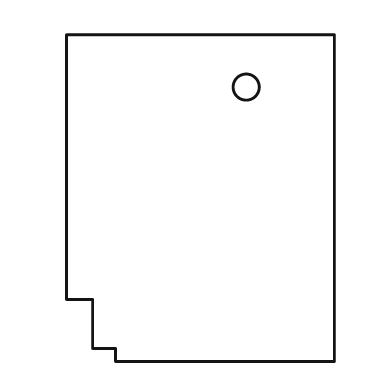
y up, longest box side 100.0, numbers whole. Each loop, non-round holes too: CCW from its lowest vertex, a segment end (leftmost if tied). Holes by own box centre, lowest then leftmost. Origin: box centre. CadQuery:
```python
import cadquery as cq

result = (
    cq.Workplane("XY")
    .moveTo(-26.0, -50.0)
    .lineTo(41.0, -50.0)
    .lineTo(41.0, 50.0)
    .lineTo(-41.0, 50.0)
    .lineTo(-41.0, -31.0)
    .lineTo(-33.0, -31.0)
    .lineTo(-33.0, -46.0)
    .lineTo(-26.0, -46.0)
    .close()
    .moveTo(14.0, 34.0)
    .circle(4.0)
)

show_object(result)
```